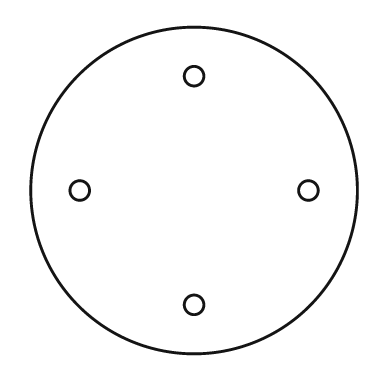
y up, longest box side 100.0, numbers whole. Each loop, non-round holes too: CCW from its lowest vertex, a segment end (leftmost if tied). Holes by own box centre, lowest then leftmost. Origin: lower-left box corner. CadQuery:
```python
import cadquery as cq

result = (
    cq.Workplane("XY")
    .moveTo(50.0, 50.0)
    .circle(50.0)
    .moveTo(50.0, 15.0)
    .circle(3.0)
    .moveTo(15.0, 50.0)
    .circle(3.0)
    .moveTo(85.0, 50.0)
    .circle(3.0)
    .moveTo(50.0, 85.0)
    .circle(3.0)
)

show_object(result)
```